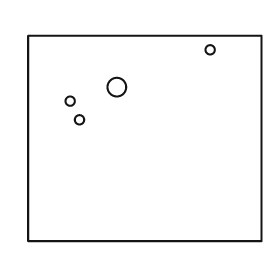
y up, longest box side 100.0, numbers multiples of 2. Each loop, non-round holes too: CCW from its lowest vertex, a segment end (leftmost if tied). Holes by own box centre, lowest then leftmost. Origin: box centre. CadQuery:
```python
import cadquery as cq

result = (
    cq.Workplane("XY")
    .moveTo(-50.0, -44.0)
    .lineTo(50.0, -44.0)
    .lineTo(50.0, 44.0)
    .lineTo(-50.0, 44.0)
    .close()
    .moveTo(-28.0, 8.0)
    .circle(2.0)
    .moveTo(-32.0, 16.0)
    .circle(2.0)
    .moveTo(-12.0, 22.0)
    .circle(4.0)
    .moveTo(28.0, 38.0)
    .circle(2.0)
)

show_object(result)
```